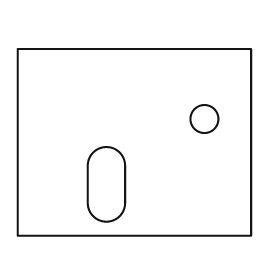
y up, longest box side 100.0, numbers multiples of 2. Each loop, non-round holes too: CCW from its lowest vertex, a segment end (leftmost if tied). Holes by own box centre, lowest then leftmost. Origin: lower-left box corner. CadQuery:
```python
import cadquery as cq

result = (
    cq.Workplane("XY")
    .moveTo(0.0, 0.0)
    .lineTo(100.0, 0.0)
    .lineTo(100.0, 80.0)
    .lineTo(0.0, 80.0)
    .close()
    .moveTo(30.0, 14.0)
    .threePointArc((38.0, 6.0), (46.0, 14.0))
    .lineTo(46.0, 30.0)
    .threePointArc((38.0, 38.0), (30.0, 30.0))
    .close()
    .moveTo(80.0, 50.0)
    .circle(6.0)
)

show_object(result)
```